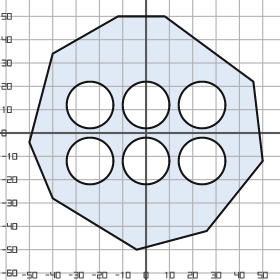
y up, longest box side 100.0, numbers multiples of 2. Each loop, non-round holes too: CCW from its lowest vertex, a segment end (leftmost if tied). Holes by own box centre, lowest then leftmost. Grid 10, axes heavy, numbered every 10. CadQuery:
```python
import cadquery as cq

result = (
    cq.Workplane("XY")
    .moveTo(-4.0, -50.0)
    .lineTo(26.0, -42.0)
    .lineTo(50.0, -12.0)
    .lineTo(46.0, 22.0)
    .lineTo(8.0, 50.0)
    .lineTo(-12.0, 50.0)
    .lineTo(-40.0, 34.0)
    .lineTo(-50.0, -4.0)
    .lineTo(-40.0, -28.0)
    .close()
    .moveTo(-24.0, -12.0)
    .circle(10.0)
    .moveTo(0.0, -12.0)
    .circle(10.0)
    .moveTo(24.0, -12.0)
    .circle(10.0)
    .moveTo(-24.0, 12.0)
    .circle(10.0)
    .moveTo(0.0, 12.0)
    .circle(10.0)
    .moveTo(24.0, 12.0)
    .circle(10.0)
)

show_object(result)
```